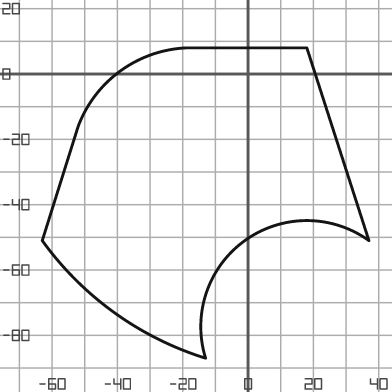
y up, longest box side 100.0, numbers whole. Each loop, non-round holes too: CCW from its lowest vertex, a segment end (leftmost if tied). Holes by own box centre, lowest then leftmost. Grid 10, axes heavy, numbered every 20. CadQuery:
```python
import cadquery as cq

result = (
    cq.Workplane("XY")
    .moveTo(-13.0, -87.0)
    .threePointArc((-1.0, -51.0), (37.0, -51.0))
    .lineTo(18.0, 8.0)
    .lineTo(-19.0, 8.0)
    .threePointArc((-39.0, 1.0), (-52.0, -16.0))
    .lineTo(-63.0, -51.0)
    .threePointArc((-41.0, -73.0), (-13.0, -87.0))
    .close()
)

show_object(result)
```